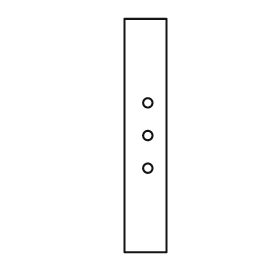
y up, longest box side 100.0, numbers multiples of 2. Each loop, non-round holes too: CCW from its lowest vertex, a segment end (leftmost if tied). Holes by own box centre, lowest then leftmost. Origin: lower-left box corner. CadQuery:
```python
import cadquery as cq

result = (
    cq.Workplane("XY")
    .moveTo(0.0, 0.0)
    .lineTo(18.0, 0.0)
    .lineTo(18.0, 100.0)
    .lineTo(0.0, 100.0)
    .close()
    .moveTo(10.0, 36.0)
    .circle(2.0)
    .moveTo(10.0, 50.0)
    .circle(2.0)
    .moveTo(10.0, 64.0)
    .circle(2.0)
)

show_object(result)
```